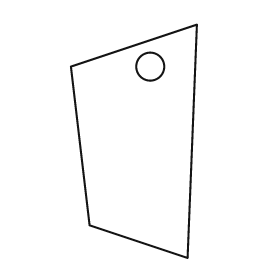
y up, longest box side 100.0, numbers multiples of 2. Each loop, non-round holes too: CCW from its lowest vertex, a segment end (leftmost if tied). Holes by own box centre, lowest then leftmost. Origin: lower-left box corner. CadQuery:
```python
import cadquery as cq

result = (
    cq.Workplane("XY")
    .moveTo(50.0, 0.0)
    .lineTo(54.0, 100.0)
    .lineTo(0.0, 82.0)
    .lineTo(8.0, 14.0)
    .close()
    .moveTo(34.0, 82.0)
    .circle(6.0)
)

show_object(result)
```